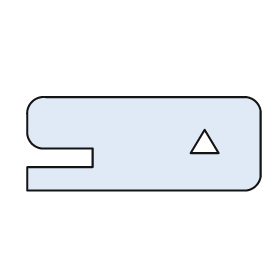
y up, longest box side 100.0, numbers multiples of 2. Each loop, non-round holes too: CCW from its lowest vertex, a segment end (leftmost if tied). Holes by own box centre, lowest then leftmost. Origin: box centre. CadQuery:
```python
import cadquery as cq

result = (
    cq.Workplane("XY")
    .moveTo(-50.0, -20.0)
    .lineTo(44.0, -20.0)
    .threePointArc((48.0, -18.0), (50.0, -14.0))
    .lineTo(50.0, 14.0)
    .threePointArc((48.0, 18.0), (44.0, 20.0))
    .lineTo(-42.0, 20.0)
    .threePointArc((-48.0, 18.0), (-50.0, 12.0))
    .lineTo(-50.0, 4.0)
    .threePointArc((-48.0, 0.0), (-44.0, -2.0))
    .lineTo(-22.0, -2.0)
    .lineTo(-22.0, -10.0)
    .lineTo(-50.0, -10.0)
    .close()
    .moveTo(20.0, -4.0)
    .lineTo(32.0, -4.0)
    .lineTo(26.0, 6.0)
    .close()
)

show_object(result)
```